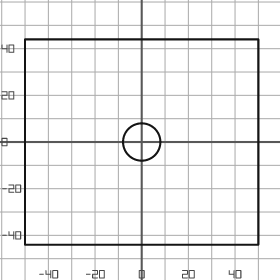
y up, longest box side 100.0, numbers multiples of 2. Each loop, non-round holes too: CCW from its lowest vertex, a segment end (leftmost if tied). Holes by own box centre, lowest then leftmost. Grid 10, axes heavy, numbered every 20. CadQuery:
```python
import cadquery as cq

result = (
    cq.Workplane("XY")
    .moveTo(-50.0, -44.0)
    .lineTo(50.0, -44.0)
    .lineTo(50.0, 44.0)
    .lineTo(-50.0, 44.0)
    .close()
    .moveTo(0.0, 0.0)
    .circle(8.0)
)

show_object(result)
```